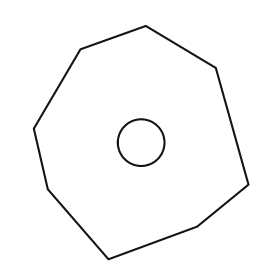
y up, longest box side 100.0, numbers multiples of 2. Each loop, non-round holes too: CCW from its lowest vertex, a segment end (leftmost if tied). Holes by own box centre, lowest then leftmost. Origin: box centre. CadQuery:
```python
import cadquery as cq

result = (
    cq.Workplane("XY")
    .moveTo(-14.0, -50.0)
    .lineTo(24.0, -36.0)
    .lineTo(46.0, -18.0)
    .lineTo(32.0, 32.0)
    .lineTo(2.0, 50.0)
    .lineTo(-26.0, 40.0)
    .lineTo(-46.0, 6.0)
    .lineTo(-40.0, -20.0)
    .close()
    .moveTo(0.0, 0.0)
    .circle(10.0)
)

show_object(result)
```